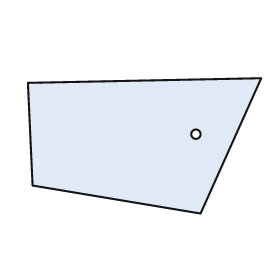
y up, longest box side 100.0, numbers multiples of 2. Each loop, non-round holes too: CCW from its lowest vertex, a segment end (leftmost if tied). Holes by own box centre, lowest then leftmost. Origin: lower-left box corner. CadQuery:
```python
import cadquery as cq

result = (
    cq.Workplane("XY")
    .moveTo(74.0, 0.0)
    .lineTo(100.0, 58.0)
    .lineTo(0.0, 56.0)
    .lineTo(2.0, 12.0)
    .close()
    .moveTo(72.0, 34.0)
    .circle(2.0)
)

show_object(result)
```